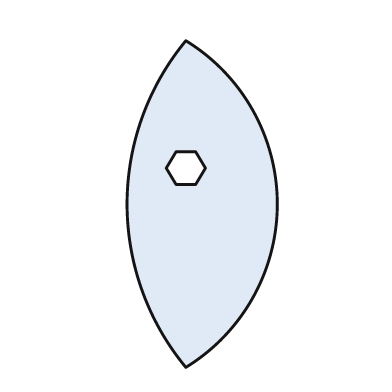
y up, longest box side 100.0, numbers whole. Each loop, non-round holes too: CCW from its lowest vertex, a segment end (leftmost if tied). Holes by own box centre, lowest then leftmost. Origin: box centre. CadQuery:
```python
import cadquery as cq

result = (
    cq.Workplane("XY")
    .moveTo(-5.0, -50.0)
    .threePointArc((23.0, 0.0), (-5.0, 50.0))
    .threePointArc((-23.0, 0.0), (-5.0, -50.0))
    .close()
    .moveTo(-8.0, 6.0)
    .lineTo(-2.0, 6.0)
    .lineTo(1.0, 11.0)
    .lineTo(-2.0, 16.0)
    .lineTo(-8.0, 16.0)
    .lineTo(-11.0, 11.0)
    .close()
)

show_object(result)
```